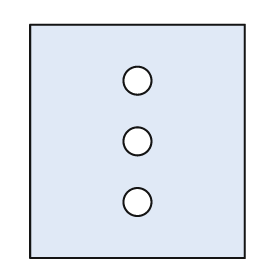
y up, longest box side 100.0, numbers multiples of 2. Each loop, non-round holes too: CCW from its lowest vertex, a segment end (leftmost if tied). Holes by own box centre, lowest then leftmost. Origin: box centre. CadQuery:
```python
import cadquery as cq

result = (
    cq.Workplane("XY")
    .moveTo(-46.0, -50.0)
    .lineTo(46.0, -50.0)
    .lineTo(46.0, 50.0)
    .lineTo(-46.0, 50.0)
    .close()
    .moveTo(0.0, -26.0)
    .circle(6.0)
    .moveTo(0.0, 0.0)
    .circle(6.0)
    .moveTo(0.0, 26.0)
    .circle(6.0)
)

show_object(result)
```